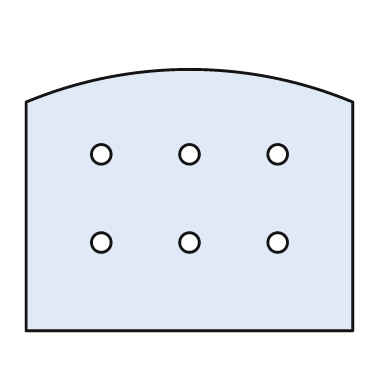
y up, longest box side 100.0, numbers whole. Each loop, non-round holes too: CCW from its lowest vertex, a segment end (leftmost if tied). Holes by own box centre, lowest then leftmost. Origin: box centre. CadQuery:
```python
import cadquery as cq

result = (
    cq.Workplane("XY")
    .moveTo(-50.0, -40.0)
    .lineTo(50.0, -40.0)
    .lineTo(50.0, 30.0)
    .threePointArc((0.0, 40.0), (-50.0, 30.0))
    .close()
    .moveTo(-27.0, -13.0)
    .circle(3.0)
    .moveTo(0.0, -13.0)
    .circle(3.0)
    .moveTo(27.0, -13.0)
    .circle(3.0)
    .moveTo(-27.0, 14.0)
    .circle(3.0)
    .moveTo(0.0, 14.0)
    .circle(3.0)
    .moveTo(27.0, 14.0)
    .circle(3.0)
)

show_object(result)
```